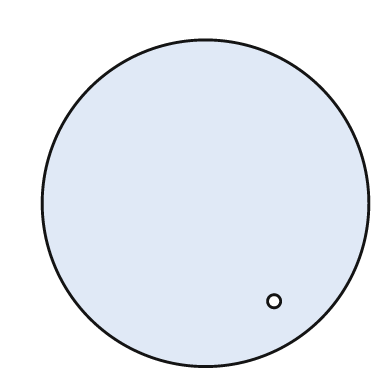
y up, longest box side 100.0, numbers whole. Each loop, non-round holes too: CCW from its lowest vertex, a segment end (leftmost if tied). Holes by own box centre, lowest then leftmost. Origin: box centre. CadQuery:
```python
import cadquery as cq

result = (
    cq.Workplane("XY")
    .moveTo(0.0, 0.0)
    .circle(50.0)
    .moveTo(21.0, -30.0)
    .circle(2.0)
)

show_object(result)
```